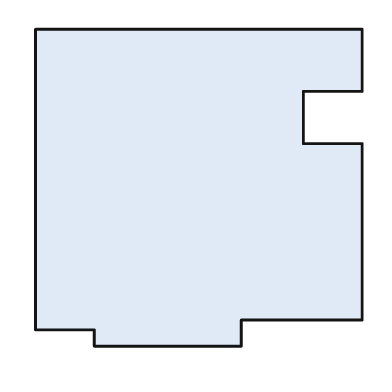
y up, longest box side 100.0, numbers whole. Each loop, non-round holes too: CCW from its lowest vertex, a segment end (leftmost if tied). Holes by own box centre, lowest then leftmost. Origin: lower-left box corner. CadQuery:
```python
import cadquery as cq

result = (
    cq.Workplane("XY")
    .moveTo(18.0, 0.0)
    .lineTo(63.0, 0.0)
    .lineTo(63.0, 8.0)
    .lineTo(100.0, 8.0)
    .lineTo(100.0, 62.0)
    .lineTo(82.0, 62.0)
    .lineTo(82.0, 78.0)
    .lineTo(100.0, 78.0)
    .lineTo(100.0, 97.0)
    .lineTo(0.0, 97.0)
    .lineTo(0.0, 5.0)
    .lineTo(18.0, 5.0)
    .close()
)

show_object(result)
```